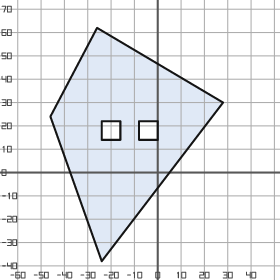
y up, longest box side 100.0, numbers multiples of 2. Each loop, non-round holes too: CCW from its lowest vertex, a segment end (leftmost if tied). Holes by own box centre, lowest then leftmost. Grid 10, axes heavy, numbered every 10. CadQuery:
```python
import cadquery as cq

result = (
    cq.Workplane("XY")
    .moveTo(-24.0, -38.0)
    .lineTo(28.0, 30.0)
    .lineTo(-26.0, 62.0)
    .lineTo(-46.0, 24.0)
    .close()
    .moveTo(-24.0, 14.0)
    .lineTo(-16.0, 14.0)
    .lineTo(-16.0, 22.0)
    .lineTo(-24.0, 22.0)
    .close()
    .moveTo(-8.0, 14.0)
    .lineTo(0.0, 14.0)
    .lineTo(0.0, 22.0)
    .lineTo(-8.0, 22.0)
    .close()
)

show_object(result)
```